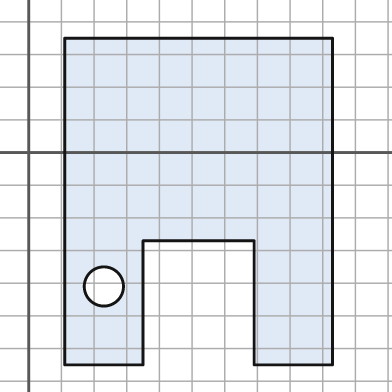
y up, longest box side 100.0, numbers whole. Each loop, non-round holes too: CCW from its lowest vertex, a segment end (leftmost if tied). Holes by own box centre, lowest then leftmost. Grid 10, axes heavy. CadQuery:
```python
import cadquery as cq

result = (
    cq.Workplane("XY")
    .moveTo(11.0, -65.0)
    .lineTo(35.0, -65.0)
    .lineTo(35.0, -27.0)
    .lineTo(69.0, -27.0)
    .lineTo(69.0, -65.0)
    .lineTo(93.0, -65.0)
    .lineTo(93.0, 35.0)
    .lineTo(11.0, 35.0)
    .close()
    .moveTo(23.0, -41.0)
    .circle(6.0)
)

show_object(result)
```